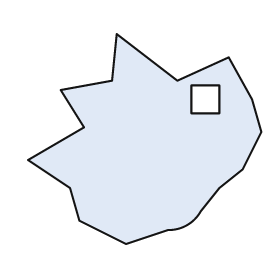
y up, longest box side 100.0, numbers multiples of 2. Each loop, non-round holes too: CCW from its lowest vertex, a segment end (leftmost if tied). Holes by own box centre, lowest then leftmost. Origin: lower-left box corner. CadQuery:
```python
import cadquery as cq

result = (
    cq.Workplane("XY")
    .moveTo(42.0, 0.0)
    .lineTo(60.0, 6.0)
    .threePointArc((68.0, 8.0), (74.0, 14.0))
    .lineTo(82.0, 24.0)
    .lineTo(92.0, 32.0)
    .lineTo(100.0, 48.0)
    .lineTo(96.0, 62.0)
    .lineTo(86.0, 80.0)
    .lineTo(64.0, 70.0)
    .lineTo(38.0, 90.0)
    .lineTo(36.0, 70.0)
    .lineTo(14.0, 66.0)
    .lineTo(24.0, 50.0)
    .lineTo(0.0, 36.0)
    .lineTo(18.0, 24.0)
    .lineTo(22.0, 10.0)
    .close()
    .moveTo(70.0, 56.0)
    .lineTo(82.0, 56.0)
    .lineTo(82.0, 68.0)
    .lineTo(70.0, 68.0)
    .close()
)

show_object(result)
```